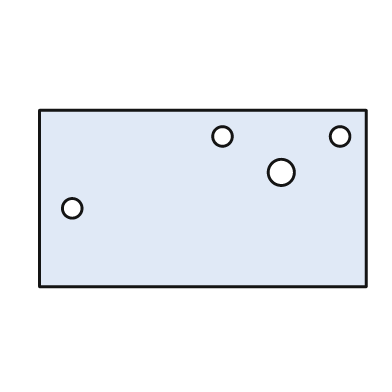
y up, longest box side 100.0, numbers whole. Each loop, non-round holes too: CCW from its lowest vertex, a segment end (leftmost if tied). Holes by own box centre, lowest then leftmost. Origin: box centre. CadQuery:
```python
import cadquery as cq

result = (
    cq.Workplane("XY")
    .moveTo(-50.0, -27.0)
    .lineTo(50.0, -27.0)
    .lineTo(50.0, 27.0)
    .lineTo(-50.0, 27.0)
    .close()
    .moveTo(-40.0, -3.0)
    .circle(3.0)
    .moveTo(24.0, 8.0)
    .circle(4.0)
    .moveTo(6.0, 19.0)
    .circle(3.0)
    .moveTo(42.0, 19.0)
    .circle(3.0)
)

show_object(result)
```